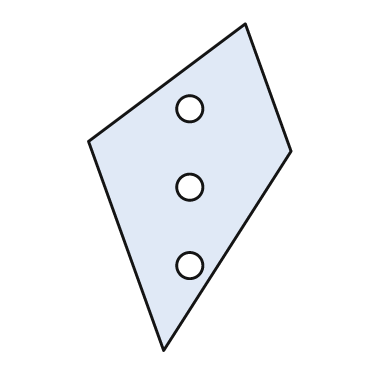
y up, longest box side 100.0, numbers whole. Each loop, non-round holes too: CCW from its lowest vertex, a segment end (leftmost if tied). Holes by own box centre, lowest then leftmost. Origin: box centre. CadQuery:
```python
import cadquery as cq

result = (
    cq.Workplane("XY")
    .moveTo(-8.0, -50.0)
    .lineTo(31.0, 11.0)
    .lineTo(17.0, 50.0)
    .lineTo(-31.0, 14.0)
    .close()
    .moveTo(0.0, -24.0)
    .circle(4.0)
    .moveTo(0.0, 0.0)
    .circle(4.0)
    .moveTo(0.0, 24.0)
    .circle(4.0)
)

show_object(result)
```